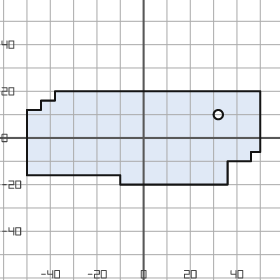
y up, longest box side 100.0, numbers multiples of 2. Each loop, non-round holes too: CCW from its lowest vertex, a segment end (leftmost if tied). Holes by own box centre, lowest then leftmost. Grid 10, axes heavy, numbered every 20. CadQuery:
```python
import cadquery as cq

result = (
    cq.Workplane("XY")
    .moveTo(-10.0, -20.0)
    .lineTo(36.0, -20.0)
    .lineTo(36.0, -10.0)
    .lineTo(46.0, -10.0)
    .lineTo(46.0, -6.0)
    .lineTo(50.0, -6.0)
    .lineTo(50.0, 20.0)
    .lineTo(-38.0, 20.0)
    .lineTo(-38.0, 16.0)
    .lineTo(-44.0, 16.0)
    .lineTo(-44.0, 12.0)
    .lineTo(-50.0, 12.0)
    .lineTo(-50.0, -16.0)
    .lineTo(-10.0, -16.0)
    .close()
    .moveTo(32.0, 10.0)
    .circle(2.0)
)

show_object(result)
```